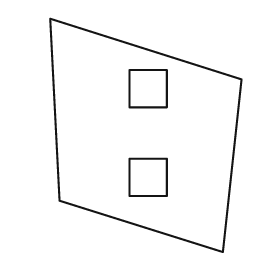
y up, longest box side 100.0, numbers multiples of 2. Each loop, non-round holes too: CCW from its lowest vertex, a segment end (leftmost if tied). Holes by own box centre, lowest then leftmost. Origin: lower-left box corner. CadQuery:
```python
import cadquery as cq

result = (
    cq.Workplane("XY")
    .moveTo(74.0, 0.0)
    .lineTo(82.0, 74.0)
    .lineTo(0.0, 100.0)
    .lineTo(4.0, 22.0)
    .close()
    .moveTo(34.0, 24.0)
    .lineTo(50.0, 24.0)
    .lineTo(50.0, 40.0)
    .lineTo(34.0, 40.0)
    .close()
    .moveTo(34.0, 62.0)
    .lineTo(50.0, 62.0)
    .lineTo(50.0, 78.0)
    .lineTo(34.0, 78.0)
    .close()
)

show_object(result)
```